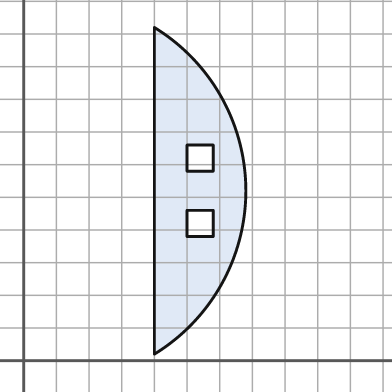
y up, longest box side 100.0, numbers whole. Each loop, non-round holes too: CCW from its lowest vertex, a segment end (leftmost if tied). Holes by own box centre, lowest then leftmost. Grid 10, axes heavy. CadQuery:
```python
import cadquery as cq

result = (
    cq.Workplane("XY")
    .moveTo(40.0, 2.0)
    .threePointArc((68.0, 52.0), (40.0, 102.0))
    .close()
    .moveTo(50.0, 38.0)
    .lineTo(58.0, 38.0)
    .lineTo(58.0, 46.0)
    .lineTo(50.0, 46.0)
    .close()
    .moveTo(50.0, 58.0)
    .lineTo(58.0, 58.0)
    .lineTo(58.0, 66.0)
    .lineTo(50.0, 66.0)
    .close()
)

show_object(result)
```